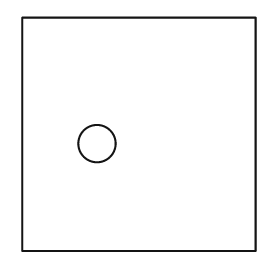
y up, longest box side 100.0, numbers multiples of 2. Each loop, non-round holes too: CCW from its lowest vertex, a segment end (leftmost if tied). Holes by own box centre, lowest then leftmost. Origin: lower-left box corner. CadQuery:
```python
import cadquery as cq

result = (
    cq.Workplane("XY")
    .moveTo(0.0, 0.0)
    .lineTo(100.0, 0.0)
    .lineTo(100.0, 100.0)
    .lineTo(0.0, 100.0)
    .close()
    .moveTo(32.0, 46.0)
    .circle(8.0)
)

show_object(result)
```